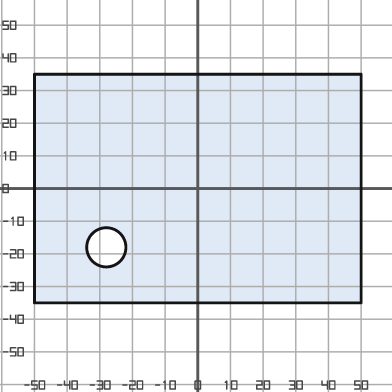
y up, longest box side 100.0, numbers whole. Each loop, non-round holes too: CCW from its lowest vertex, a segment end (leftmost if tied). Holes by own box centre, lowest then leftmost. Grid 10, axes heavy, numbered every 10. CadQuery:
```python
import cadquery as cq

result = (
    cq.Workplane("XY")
    .moveTo(-50.0, -35.0)
    .lineTo(50.0, -35.0)
    .lineTo(50.0, 35.0)
    .lineTo(-50.0, 35.0)
    .close()
    .moveTo(-28.0, -18.0)
    .circle(6.0)
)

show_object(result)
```